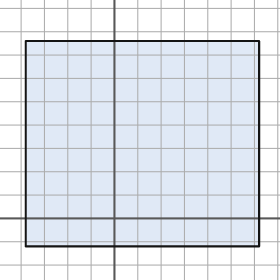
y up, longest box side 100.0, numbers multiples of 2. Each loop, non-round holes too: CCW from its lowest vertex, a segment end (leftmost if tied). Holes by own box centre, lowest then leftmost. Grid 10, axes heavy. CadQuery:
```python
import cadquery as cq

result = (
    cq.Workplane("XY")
    .moveTo(-38.0, -12.0)
    .lineTo(62.0, -12.0)
    .lineTo(62.0, 76.0)
    .lineTo(-38.0, 76.0)
    .close()
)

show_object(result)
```